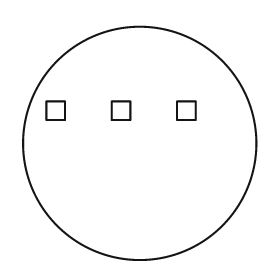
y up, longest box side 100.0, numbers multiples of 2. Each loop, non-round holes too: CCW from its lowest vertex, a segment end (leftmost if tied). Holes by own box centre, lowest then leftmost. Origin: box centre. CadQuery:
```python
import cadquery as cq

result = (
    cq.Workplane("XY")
    .moveTo(0.0, 0.0)
    .circle(50.0)
    .moveTo(-40.0, 10.0)
    .lineTo(-32.0, 10.0)
    .lineTo(-32.0, 18.0)
    .lineTo(-40.0, 18.0)
    .close()
    .moveTo(-12.0, 10.0)
    .lineTo(-4.0, 10.0)
    .lineTo(-4.0, 18.0)
    .lineTo(-12.0, 18.0)
    .close()
    .moveTo(16.0, 10.0)
    .lineTo(24.0, 10.0)
    .lineTo(24.0, 18.0)
    .lineTo(16.0, 18.0)
    .close()
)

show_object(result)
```